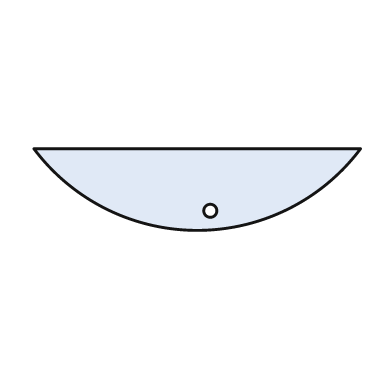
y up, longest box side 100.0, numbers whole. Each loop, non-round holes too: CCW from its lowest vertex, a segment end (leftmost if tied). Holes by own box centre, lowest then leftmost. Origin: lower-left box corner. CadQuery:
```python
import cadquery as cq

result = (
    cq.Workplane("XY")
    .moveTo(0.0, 25.0)
    .threePointArc((50.0, 0.0), (100.0, 25.0))
    .close()
    .moveTo(54.0, 6.0)
    .circle(2.0)
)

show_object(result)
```